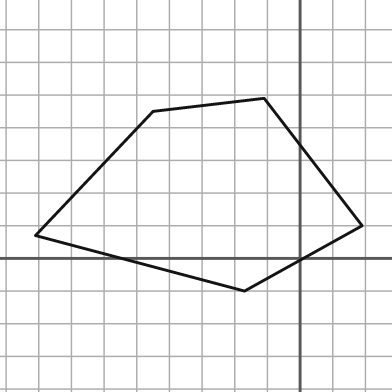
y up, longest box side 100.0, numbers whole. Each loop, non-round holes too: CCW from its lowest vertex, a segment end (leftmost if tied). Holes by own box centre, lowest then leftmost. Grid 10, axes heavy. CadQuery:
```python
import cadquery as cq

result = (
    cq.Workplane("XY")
    .moveTo(-17.0, -10.0)
    .lineTo(19.0, 10.0)
    .lineTo(-11.0, 49.0)
    .lineTo(-45.0, 45.0)
    .lineTo(-81.0, 7.0)
    .close()
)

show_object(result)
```